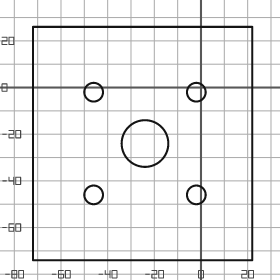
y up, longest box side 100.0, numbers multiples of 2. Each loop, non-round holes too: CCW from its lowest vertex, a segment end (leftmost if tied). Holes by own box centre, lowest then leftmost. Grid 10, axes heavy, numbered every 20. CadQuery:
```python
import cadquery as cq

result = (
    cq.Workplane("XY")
    .moveTo(-72.0, -74.0)
    .lineTo(22.0, -74.0)
    .lineTo(22.0, 26.0)
    .lineTo(-72.0, 26.0)
    .close()
    .moveTo(-46.0, -46.0)
    .circle(4.0)
    .moveTo(-2.0, -46.0)
    .circle(4.0)
    .moveTo(-24.0, -24.0)
    .circle(10.0)
    .moveTo(-46.0, -2.0)
    .circle(4.0)
    .moveTo(-2.0, -2.0)
    .circle(4.0)
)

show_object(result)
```